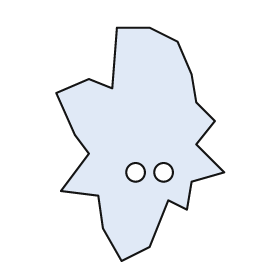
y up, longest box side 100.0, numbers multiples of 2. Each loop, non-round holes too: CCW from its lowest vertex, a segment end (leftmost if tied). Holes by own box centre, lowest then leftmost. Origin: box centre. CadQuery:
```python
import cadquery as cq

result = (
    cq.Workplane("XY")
    .moveTo(-8.0, -50.0)
    .lineTo(4.0, -44.0)
    .lineTo(12.0, -24.0)
    .lineTo(20.0, -28.0)
    .lineTo(22.0, -16.0)
    .lineTo(36.0, -12.0)
    .lineTo(24.0, 0.0)
    .lineTo(32.0, 10.0)
    .lineTo(24.0, 18.0)
    .lineTo(22.0, 30.0)
    .lineTo(16.0, 44.0)
    .lineTo(4.0, 50.0)
    .lineTo(-10.0, 50.0)
    .lineTo(-12.0, 24.0)
    .lineTo(-22.0, 28.0)
    .lineTo(-36.0, 22.0)
    .lineTo(-28.0, 4.0)
    .lineTo(-22.0, -4.0)
    .lineTo(-34.0, -20.0)
    .lineTo(-18.0, -22.0)
    .lineTo(-16.0, -36.0)
    .close()
    .moveTo(-2.0, -12.0)
    .circle(4.0)
    .moveTo(10.0, -12.0)
    .circle(4.0)
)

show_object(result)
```